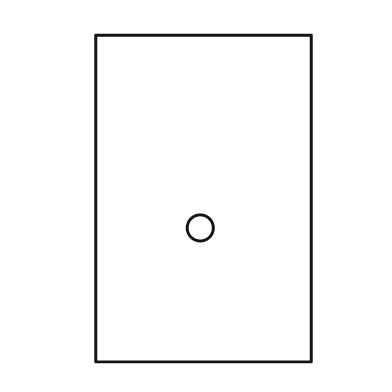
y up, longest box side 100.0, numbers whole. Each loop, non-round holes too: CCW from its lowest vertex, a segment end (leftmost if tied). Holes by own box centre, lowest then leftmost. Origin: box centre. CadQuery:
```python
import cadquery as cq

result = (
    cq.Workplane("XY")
    .moveTo(-33.0, -50.0)
    .lineTo(33.0, -50.0)
    .lineTo(33.0, 50.0)
    .lineTo(-33.0, 50.0)
    .close()
    .moveTo(-1.0, -9.0)
    .circle(4.0)
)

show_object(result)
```